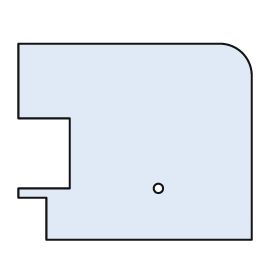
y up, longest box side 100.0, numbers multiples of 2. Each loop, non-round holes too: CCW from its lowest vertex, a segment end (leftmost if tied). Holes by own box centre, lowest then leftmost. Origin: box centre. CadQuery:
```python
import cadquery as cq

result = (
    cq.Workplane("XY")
    .moveTo(-38.0, -42.0)
    .lineTo(50.0, -42.0)
    .lineTo(50.0, 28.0)
    .threePointArc((46.0, 38.0), (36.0, 42.0))
    .lineTo(-50.0, 42.0)
    .lineTo(-50.0, 10.0)
    .lineTo(-28.0, 10.0)
    .lineTo(-28.0, -20.0)
    .lineTo(-50.0, -20.0)
    .lineTo(-50.0, -24.0)
    .lineTo(-38.0, -24.0)
    .close()
    .moveTo(10.0, -20.0)
    .circle(2.0)
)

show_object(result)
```